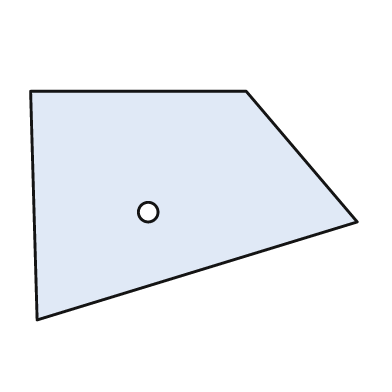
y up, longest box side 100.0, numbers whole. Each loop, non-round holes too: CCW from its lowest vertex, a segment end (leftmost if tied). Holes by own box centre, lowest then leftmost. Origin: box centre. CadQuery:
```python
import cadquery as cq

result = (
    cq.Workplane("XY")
    .moveTo(-48.0, -35.0)
    .lineTo(50.0, -5.0)
    .lineTo(16.0, 35.0)
    .lineTo(-50.0, 35.0)
    .close()
    .moveTo(-14.0, -2.0)
    .circle(3.0)
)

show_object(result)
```